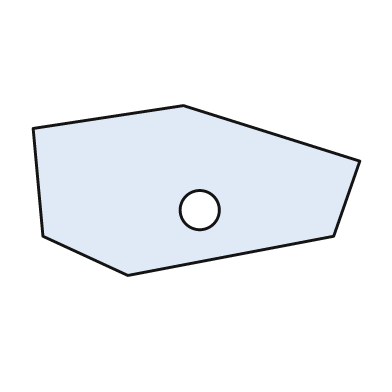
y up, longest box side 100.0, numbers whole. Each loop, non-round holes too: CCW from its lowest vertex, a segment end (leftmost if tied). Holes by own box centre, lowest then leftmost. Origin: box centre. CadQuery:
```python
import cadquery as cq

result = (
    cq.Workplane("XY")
    .moveTo(-21.0, -26.0)
    .lineTo(42.0, -14.0)
    .lineTo(50.0, 9.0)
    .lineTo(-4.0, 26.0)
    .lineTo(-50.0, 19.0)
    .lineTo(-47.0, -14.0)
    .close()
    .moveTo(1.0, -6.0)
    .circle(6.0)
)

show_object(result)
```